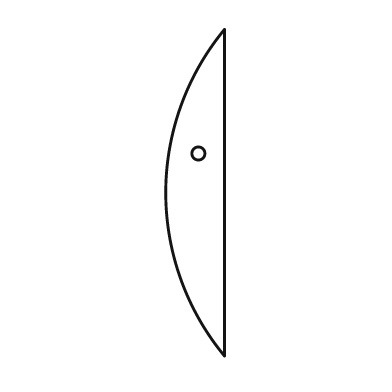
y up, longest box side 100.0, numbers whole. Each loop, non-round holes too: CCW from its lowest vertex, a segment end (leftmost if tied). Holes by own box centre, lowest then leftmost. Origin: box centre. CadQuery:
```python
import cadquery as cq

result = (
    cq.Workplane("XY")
    .moveTo(9.0, -50.0)
    .lineTo(9.0, 50.0)
    .threePointArc((-9.0, 0.0), (9.0, -50.0))
    .close()
    .moveTo(1.0, 12.0)
    .circle(2.0)
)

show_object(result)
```